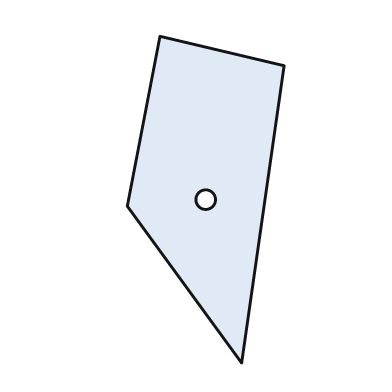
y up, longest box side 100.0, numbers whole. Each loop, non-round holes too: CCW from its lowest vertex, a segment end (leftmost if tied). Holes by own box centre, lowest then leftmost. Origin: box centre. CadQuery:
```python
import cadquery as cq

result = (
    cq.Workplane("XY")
    .moveTo(11.0, -50.0)
    .lineTo(24.0, 41.0)
    .lineTo(-14.0, 50.0)
    .lineTo(-24.0, -2.0)
    .close()
    .moveTo(0.0, 0.0)
    .circle(3.0)
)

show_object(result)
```